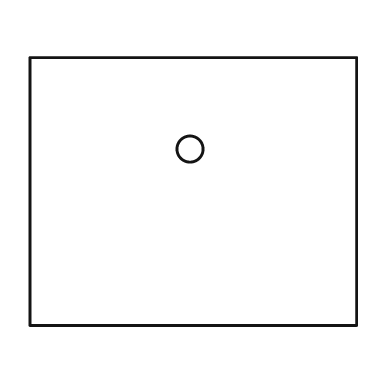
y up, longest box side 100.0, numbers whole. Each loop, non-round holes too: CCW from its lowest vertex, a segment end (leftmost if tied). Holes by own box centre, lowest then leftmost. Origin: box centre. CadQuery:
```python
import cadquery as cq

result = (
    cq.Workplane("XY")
    .moveTo(-50.0, -41.0)
    .lineTo(50.0, -41.0)
    .lineTo(50.0, 41.0)
    .lineTo(-50.0, 41.0)
    .close()
    .moveTo(-1.0, 13.0)
    .circle(4.0)
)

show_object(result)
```